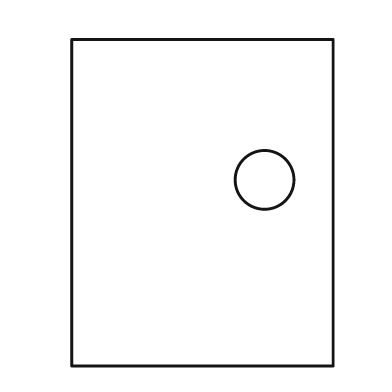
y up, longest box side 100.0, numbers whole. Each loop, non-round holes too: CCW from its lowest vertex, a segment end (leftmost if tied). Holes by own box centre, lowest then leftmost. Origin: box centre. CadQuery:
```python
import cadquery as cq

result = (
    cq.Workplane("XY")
    .moveTo(-40.0, -50.0)
    .lineTo(40.0, -50.0)
    .lineTo(40.0, 50.0)
    .lineTo(-40.0, 50.0)
    .close()
    .moveTo(19.0, 7.0)
    .circle(9.0)
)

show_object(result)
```